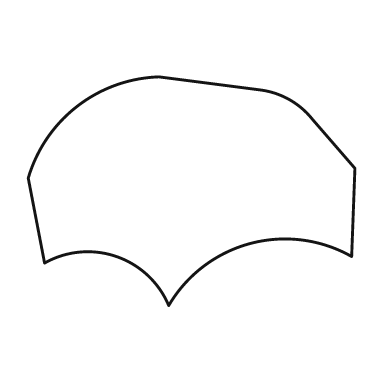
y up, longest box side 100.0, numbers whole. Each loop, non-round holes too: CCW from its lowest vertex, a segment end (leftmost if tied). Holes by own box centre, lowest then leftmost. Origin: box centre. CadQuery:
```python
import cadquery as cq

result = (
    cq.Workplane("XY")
    .moveTo(-7.0, -35.0)
    .threePointArc((18.0, -16.0), (49.0, -20.0))
    .lineTo(50.0, 7.0)
    .lineTo(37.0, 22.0)
    .threePointArc((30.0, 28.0), (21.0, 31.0))
    .lineTo(-10.0, 35.0)
    .threePointArc((-35.0, 26.0), (-50.0, 4.0))
    .lineTo(-45.0, -22.0)
    .threePointArc((-23.0, -20.0), (-7.0, -35.0))
    .close()
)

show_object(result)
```